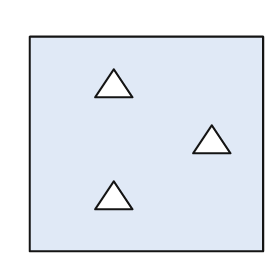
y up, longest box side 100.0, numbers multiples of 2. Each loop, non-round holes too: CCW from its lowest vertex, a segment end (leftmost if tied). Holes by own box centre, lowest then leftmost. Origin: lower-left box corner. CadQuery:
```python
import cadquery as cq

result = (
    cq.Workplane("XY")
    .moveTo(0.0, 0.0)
    .lineTo(100.0, 0.0)
    .lineTo(100.0, 92.0)
    .lineTo(0.0, 92.0)
    .close()
    .moveTo(28.0, 18.0)
    .lineTo(44.0, 18.0)
    .lineTo(36.0, 30.0)
    .close()
    .moveTo(70.0, 42.0)
    .lineTo(86.0, 42.0)
    .lineTo(78.0, 54.0)
    .close()
    .moveTo(28.0, 66.0)
    .lineTo(44.0, 66.0)
    .lineTo(36.0, 78.0)
    .close()
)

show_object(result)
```